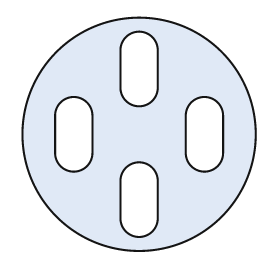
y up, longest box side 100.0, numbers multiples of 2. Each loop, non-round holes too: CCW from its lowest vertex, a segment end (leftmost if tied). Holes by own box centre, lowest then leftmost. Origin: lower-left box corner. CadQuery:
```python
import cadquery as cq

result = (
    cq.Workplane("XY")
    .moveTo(50.0, 50.0)
    .circle(50.0)
    .moveTo(42.0, 14.0)
    .threePointArc((50.0, 6.0), (58.0, 14.0))
    .lineTo(58.0, 30.0)
    .threePointArc((50.0, 38.0), (42.0, 30.0))
    .close()
    .moveTo(14.0, 42.0)
    .threePointArc((22.0, 34.0), (30.0, 42.0))
    .lineTo(30.0, 58.0)
    .threePointArc((22.0, 66.0), (14.0, 58.0))
    .close()
    .moveTo(70.0, 42.0)
    .threePointArc((78.0, 34.0), (86.0, 42.0))
    .lineTo(86.0, 58.0)
    .threePointArc((78.0, 66.0), (70.0, 58.0))
    .close()
    .moveTo(42.0, 70.0)
    .threePointArc((50.0, 62.0), (58.0, 70.0))
    .lineTo(58.0, 86.0)
    .threePointArc((50.0, 94.0), (42.0, 86.0))
    .close()
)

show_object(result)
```